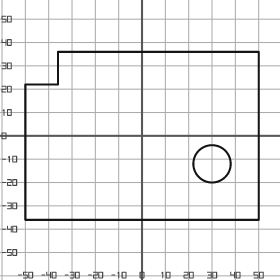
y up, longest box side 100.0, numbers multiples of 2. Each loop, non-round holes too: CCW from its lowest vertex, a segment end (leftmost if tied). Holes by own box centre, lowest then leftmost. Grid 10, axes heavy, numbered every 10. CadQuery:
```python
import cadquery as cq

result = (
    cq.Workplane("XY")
    .moveTo(-50.0, -36.0)
    .lineTo(50.0, -36.0)
    .lineTo(50.0, 36.0)
    .lineTo(-36.0, 36.0)
    .lineTo(-36.0, 22.0)
    .lineTo(-50.0, 22.0)
    .close()
    .moveTo(30.0, -12.0)
    .circle(8.0)
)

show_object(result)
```